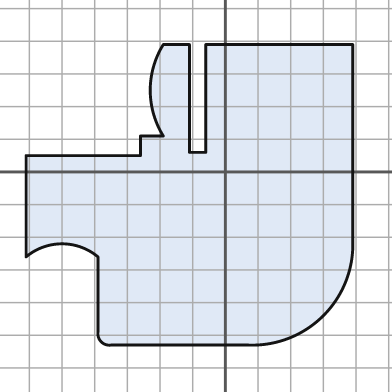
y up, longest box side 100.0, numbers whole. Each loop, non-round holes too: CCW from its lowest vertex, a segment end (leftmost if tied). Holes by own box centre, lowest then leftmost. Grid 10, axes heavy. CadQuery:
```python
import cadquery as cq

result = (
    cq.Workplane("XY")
    .moveTo(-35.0, -53.0)
    .lineTo(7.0, -53.0)
    .threePointArc((30.0, -44.0), (39.0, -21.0))
    .lineTo(39.0, 39.0)
    .lineTo(-6.0, 39.0)
    .lineTo(-6.0, 6.0)
    .lineTo(-11.0, 6.0)
    .lineTo(-11.0, 39.0)
    .lineTo(-19.0, 39.0)
    .threePointArc((-23.0, 25.0), (-19.0, 11.0))
    .lineTo(-26.0, 11.0)
    .lineTo(-26.0, 5.0)
    .lineTo(-61.0, 5.0)
    .lineTo(-61.0, -26.0)
    .threePointArc((-50.0, -22.0), (-39.0, -26.0))
    .lineTo(-39.0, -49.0)
    .threePointArc((-38.0, -52.0), (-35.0, -53.0))
    .close()
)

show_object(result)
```